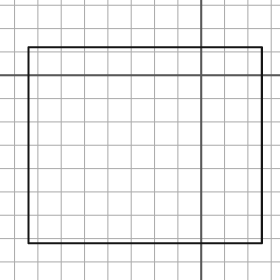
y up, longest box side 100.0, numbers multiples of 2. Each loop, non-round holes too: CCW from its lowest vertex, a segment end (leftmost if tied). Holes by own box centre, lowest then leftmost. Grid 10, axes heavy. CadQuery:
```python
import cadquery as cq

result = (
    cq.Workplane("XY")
    .moveTo(-74.0, -72.0)
    .lineTo(26.0, -72.0)
    .lineTo(26.0, 12.0)
    .lineTo(-74.0, 12.0)
    .close()
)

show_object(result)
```